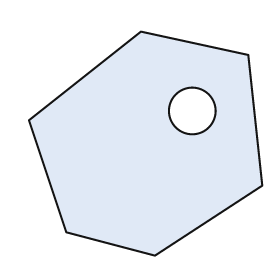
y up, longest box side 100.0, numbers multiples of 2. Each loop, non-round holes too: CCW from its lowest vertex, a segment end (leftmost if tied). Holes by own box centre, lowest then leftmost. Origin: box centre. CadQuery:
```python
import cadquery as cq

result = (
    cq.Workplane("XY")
    .moveTo(4.0, -48.0)
    .lineTo(50.0, -18.0)
    .lineTo(44.0, 38.0)
    .lineTo(-2.0, 48.0)
    .lineTo(-50.0, 10.0)
    .lineTo(-34.0, -38.0)
    .close()
    .moveTo(20.0, 14.0)
    .circle(10.0)
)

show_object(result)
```